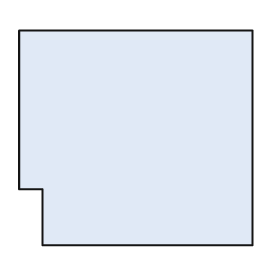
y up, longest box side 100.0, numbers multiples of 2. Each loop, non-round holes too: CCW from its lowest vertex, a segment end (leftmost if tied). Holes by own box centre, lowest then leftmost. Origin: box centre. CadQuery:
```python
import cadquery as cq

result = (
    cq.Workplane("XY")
    .moveTo(-40.0, -46.0)
    .lineTo(50.0, -46.0)
    .lineTo(50.0, 46.0)
    .lineTo(-50.0, 46.0)
    .lineTo(-50.0, -22.0)
    .lineTo(-40.0, -22.0)
    .close()
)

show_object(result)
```